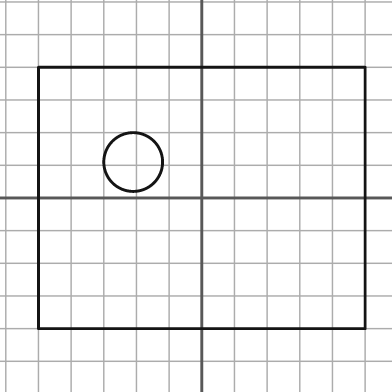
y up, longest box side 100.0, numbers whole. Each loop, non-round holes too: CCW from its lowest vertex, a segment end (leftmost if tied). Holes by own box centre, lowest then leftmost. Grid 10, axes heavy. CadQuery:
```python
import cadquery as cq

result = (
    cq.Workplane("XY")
    .moveTo(-50.0, -40.0)
    .lineTo(50.0, -40.0)
    .lineTo(50.0, 40.0)
    .lineTo(-50.0, 40.0)
    .close()
    .moveTo(-21.0, 11.0)
    .circle(9.0)
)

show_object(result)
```